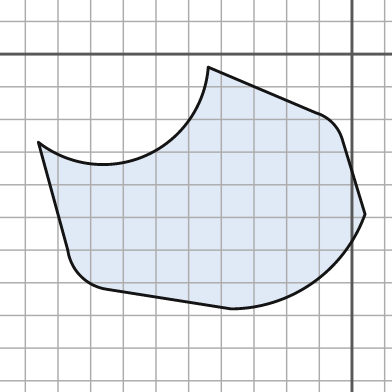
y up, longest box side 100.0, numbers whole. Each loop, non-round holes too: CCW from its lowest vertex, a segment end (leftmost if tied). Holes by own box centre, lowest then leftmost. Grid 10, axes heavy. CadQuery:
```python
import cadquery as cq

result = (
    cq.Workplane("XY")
    .moveTo(-37.0, -78.0)
    .threePointArc((-12.0, -70.0), (4.0, -49.0))
    .lineTo(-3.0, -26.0)
    .threePointArc((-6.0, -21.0), (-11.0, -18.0))
    .lineTo(-44.0, -4.0)
    .threePointArc((-63.0, -31.0), (-96.0, -27.0))
    .lineTo(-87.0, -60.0)
    .threePointArc((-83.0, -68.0), (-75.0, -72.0))
    .close()
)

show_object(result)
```